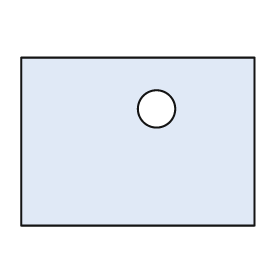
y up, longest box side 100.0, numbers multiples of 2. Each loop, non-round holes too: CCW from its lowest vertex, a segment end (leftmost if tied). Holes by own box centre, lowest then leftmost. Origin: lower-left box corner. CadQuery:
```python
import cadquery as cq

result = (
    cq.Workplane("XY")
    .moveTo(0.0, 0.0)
    .lineTo(100.0, 0.0)
    .lineTo(100.0, 72.0)
    .lineTo(0.0, 72.0)
    .close()
    .moveTo(58.0, 50.0)
    .circle(8.0)
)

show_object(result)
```